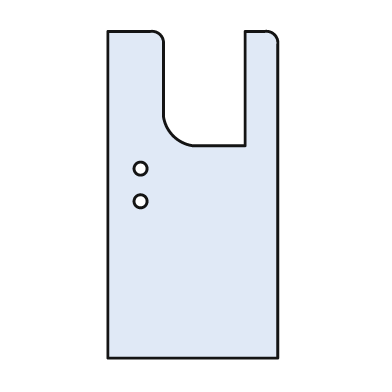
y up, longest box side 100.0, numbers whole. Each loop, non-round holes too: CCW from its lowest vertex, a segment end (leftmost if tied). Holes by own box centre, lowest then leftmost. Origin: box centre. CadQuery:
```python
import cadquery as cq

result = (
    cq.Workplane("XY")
    .moveTo(-26.0, -50.0)
    .lineTo(26.0, -50.0)
    .lineTo(26.0, 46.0)
    .threePointArc((25.0, 49.0), (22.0, 50.0))
    .lineTo(16.0, 50.0)
    .lineTo(16.0, 15.0)
    .lineTo(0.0, 15.0)
    .threePointArc((-6.0, 18.0), (-9.0, 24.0))
    .lineTo(-9.0, 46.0)
    .threePointArc((-10.0, 49.0), (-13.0, 50.0))
    .lineTo(-26.0, 50.0)
    .close()
    .moveTo(-16.0, -2.0)
    .circle(2.0)
    .moveTo(-16.0, 8.0)
    .circle(2.0)
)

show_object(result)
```